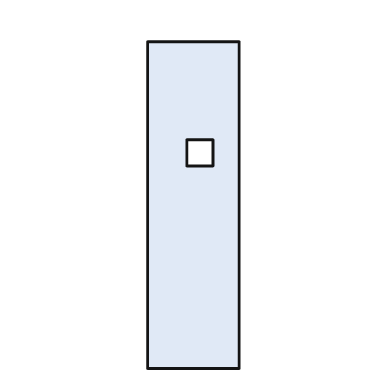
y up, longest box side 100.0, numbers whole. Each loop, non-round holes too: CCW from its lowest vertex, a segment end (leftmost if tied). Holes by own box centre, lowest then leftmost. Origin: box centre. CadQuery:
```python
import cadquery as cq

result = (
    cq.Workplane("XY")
    .moveTo(-14.0, -50.0)
    .lineTo(14.0, -50.0)
    .lineTo(14.0, 50.0)
    .lineTo(-14.0, 50.0)
    .close()
    .moveTo(-2.0, 12.0)
    .lineTo(6.0, 12.0)
    .lineTo(6.0, 20.0)
    .lineTo(-2.0, 20.0)
    .close()
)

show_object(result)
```